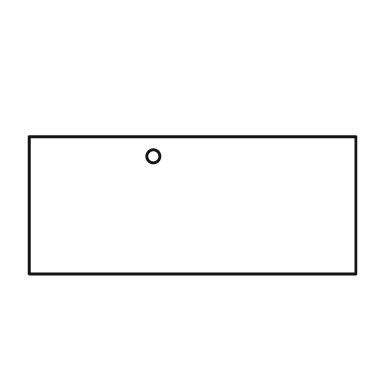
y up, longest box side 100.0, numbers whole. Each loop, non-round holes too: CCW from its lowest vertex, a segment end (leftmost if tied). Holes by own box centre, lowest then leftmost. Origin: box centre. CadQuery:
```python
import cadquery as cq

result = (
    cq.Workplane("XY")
    .moveTo(-50.0, -21.0)
    .lineTo(50.0, -21.0)
    .lineTo(50.0, 21.0)
    .lineTo(-50.0, 21.0)
    .close()
    .moveTo(-12.0, 15.0)
    .circle(2.0)
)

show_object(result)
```